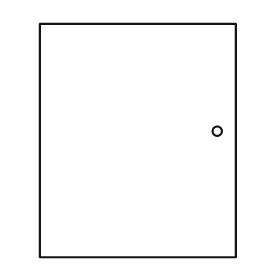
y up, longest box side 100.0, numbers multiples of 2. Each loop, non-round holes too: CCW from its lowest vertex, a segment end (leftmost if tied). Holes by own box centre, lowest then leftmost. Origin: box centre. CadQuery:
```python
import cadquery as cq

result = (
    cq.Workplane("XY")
    .moveTo(-42.0, -50.0)
    .lineTo(42.0, -50.0)
    .lineTo(42.0, 50.0)
    .lineTo(-42.0, 50.0)
    .close()
    .moveTo(34.0, 4.0)
    .circle(2.0)
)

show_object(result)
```